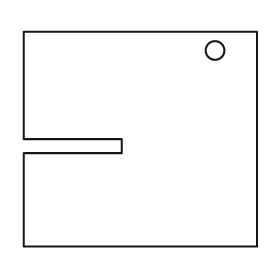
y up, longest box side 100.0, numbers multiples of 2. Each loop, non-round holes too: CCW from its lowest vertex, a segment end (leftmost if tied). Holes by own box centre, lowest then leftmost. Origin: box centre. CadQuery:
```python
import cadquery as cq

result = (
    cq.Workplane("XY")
    .moveTo(-50.0, -46.0)
    .lineTo(50.0, -46.0)
    .lineTo(50.0, 46.0)
    .lineTo(-50.0, 46.0)
    .lineTo(-50.0, 0.0)
    .lineTo(-8.0, 0.0)
    .lineTo(-8.0, -6.0)
    .lineTo(-50.0, -6.0)
    .close()
    .moveTo(32.0, 38.0)
    .circle(4.0)
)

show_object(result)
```